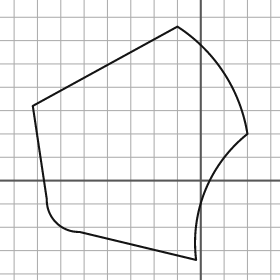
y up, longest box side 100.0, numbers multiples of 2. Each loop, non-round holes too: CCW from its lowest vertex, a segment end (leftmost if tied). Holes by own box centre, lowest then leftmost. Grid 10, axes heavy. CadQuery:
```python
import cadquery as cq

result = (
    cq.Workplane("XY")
    .moveTo(-2.0, -34.0)
    .threePointArc((2.0, -4.0), (20.0, 20.0))
    .threePointArc((10.0, 46.0), (-10.0, 66.0))
    .lineTo(-72.0, 32.0)
    .lineTo(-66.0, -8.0)
    .threePointArc((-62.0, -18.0), (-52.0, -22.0))
    .close()
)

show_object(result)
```